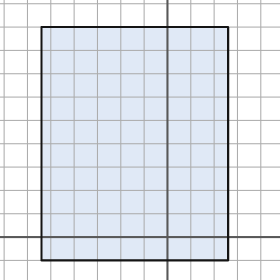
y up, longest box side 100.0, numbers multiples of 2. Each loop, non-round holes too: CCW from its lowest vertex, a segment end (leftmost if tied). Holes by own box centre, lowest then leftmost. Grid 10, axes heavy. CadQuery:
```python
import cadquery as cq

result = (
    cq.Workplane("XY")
    .moveTo(-54.0, -10.0)
    .lineTo(26.0, -10.0)
    .lineTo(26.0, 90.0)
    .lineTo(-54.0, 90.0)
    .close()
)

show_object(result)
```